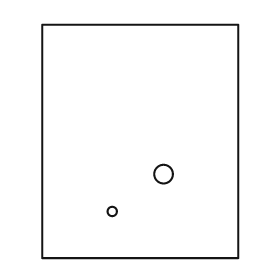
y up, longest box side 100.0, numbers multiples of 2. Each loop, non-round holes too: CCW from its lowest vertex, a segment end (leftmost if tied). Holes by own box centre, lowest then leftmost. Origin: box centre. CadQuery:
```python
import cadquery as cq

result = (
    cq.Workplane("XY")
    .moveTo(-42.0, -50.0)
    .lineTo(42.0, -50.0)
    .lineTo(42.0, 50.0)
    .lineTo(-42.0, 50.0)
    .close()
    .moveTo(-12.0, -30.0)
    .circle(2.0)
    .moveTo(10.0, -14.0)
    .circle(4.0)
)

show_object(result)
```